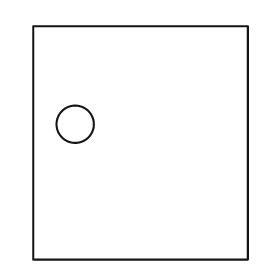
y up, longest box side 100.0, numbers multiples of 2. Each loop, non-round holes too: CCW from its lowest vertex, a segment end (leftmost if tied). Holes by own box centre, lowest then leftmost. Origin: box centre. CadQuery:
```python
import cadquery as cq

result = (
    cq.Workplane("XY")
    .moveTo(-46.0, -50.0)
    .lineTo(46.0, -50.0)
    .lineTo(46.0, 50.0)
    .lineTo(-46.0, 50.0)
    .close()
    .moveTo(-28.0, 8.0)
    .circle(8.0)
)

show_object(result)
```